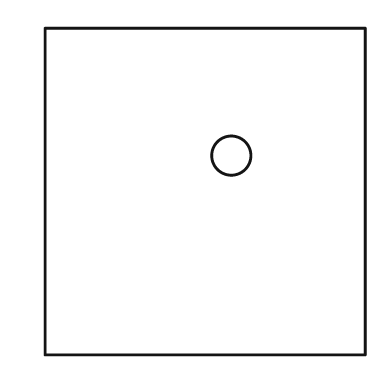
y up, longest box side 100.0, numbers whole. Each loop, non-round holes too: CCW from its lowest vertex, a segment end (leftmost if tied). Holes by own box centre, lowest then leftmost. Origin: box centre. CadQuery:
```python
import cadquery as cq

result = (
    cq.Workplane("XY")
    .moveTo(-49.0, -50.0)
    .lineTo(49.0, -50.0)
    .lineTo(49.0, 50.0)
    .lineTo(-49.0, 50.0)
    .close()
    .moveTo(8.0, 11.0)
    .circle(6.0)
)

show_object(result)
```